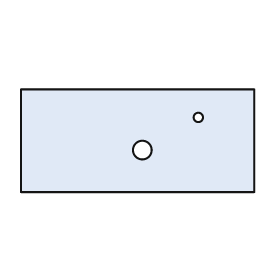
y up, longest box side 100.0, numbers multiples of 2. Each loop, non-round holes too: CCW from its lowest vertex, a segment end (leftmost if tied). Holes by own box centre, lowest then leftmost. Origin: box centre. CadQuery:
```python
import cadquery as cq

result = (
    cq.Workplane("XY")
    .moveTo(-50.0, -22.0)
    .lineTo(50.0, -22.0)
    .lineTo(50.0, 22.0)
    .lineTo(-50.0, 22.0)
    .close()
    .moveTo(2.0, -4.0)
    .circle(4.0)
    .moveTo(26.0, 10.0)
    .circle(2.0)
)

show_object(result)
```